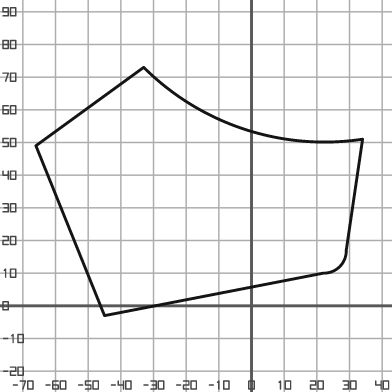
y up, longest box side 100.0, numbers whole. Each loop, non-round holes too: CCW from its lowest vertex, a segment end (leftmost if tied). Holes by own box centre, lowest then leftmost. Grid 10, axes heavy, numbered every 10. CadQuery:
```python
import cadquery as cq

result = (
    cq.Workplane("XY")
    .moveTo(-45.0, -3.0)
    .lineTo(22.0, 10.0)
    .threePointArc((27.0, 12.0), (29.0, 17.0))
    .lineTo(34.0, 51.0)
    .threePointArc((-2.0, 54.0), (-33.0, 73.0))
    .lineTo(-66.0, 49.0)
    .close()
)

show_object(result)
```